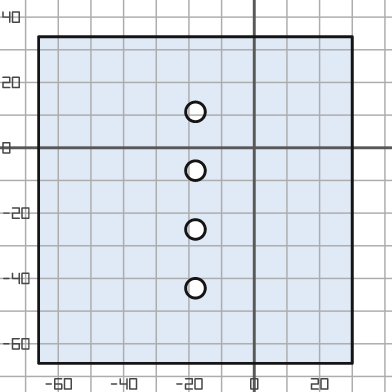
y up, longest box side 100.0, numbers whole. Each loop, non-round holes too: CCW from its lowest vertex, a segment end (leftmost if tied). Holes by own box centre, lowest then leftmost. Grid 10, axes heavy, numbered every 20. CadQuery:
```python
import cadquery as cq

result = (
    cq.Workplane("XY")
    .moveTo(-66.0, -66.0)
    .lineTo(30.0, -66.0)
    .lineTo(30.0, 34.0)
    .lineTo(-66.0, 34.0)
    .close()
    .moveTo(-18.0, -43.0)
    .circle(3.0)
    .moveTo(-18.0, -25.0)
    .circle(3.0)
    .moveTo(-18.0, -7.0)
    .circle(3.0)
    .moveTo(-18.0, 11.0)
    .circle(3.0)
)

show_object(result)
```